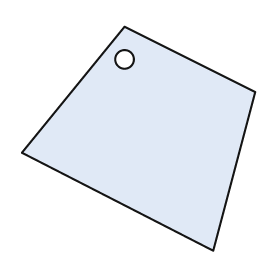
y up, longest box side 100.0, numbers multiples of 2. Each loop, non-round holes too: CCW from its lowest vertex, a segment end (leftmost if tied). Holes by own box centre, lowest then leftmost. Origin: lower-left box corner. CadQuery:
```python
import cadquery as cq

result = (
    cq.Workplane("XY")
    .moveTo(82.0, 0.0)
    .lineTo(100.0, 68.0)
    .lineTo(44.0, 96.0)
    .lineTo(0.0, 42.0)
    .close()
    .moveTo(44.0, 82.0)
    .circle(4.0)
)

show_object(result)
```